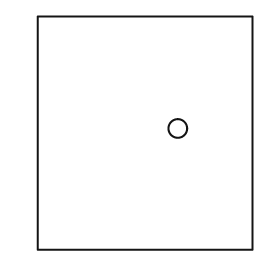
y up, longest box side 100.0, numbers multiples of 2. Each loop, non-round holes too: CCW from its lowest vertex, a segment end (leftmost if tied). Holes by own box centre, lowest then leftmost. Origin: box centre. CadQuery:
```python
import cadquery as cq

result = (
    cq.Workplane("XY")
    .moveTo(-46.0, -50.0)
    .lineTo(46.0, -50.0)
    .lineTo(46.0, 50.0)
    .lineTo(-46.0, 50.0)
    .close()
    .moveTo(14.0, 2.0)
    .circle(4.0)
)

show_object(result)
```